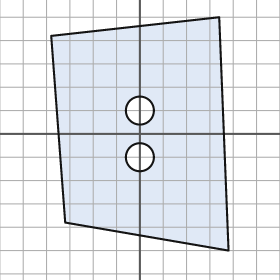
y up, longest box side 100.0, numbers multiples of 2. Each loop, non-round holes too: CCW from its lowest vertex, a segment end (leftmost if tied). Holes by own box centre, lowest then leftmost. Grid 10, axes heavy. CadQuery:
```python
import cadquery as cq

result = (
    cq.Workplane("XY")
    .moveTo(38.0, -50.0)
    .lineTo(34.0, 50.0)
    .lineTo(-38.0, 42.0)
    .lineTo(-32.0, -38.0)
    .close()
    .moveTo(0.0, -10.0)
    .circle(6.0)
    .moveTo(0.0, 10.0)
    .circle(6.0)
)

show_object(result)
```